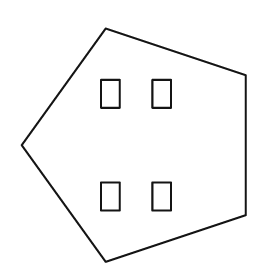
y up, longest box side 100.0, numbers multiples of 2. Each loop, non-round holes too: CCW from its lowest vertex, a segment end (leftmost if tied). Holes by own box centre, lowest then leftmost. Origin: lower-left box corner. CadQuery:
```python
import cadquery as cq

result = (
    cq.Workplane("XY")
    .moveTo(36.0, 0.0)
    .lineTo(96.0, 20.0)
    .lineTo(96.0, 80.0)
    .lineTo(36.0, 100.0)
    .lineTo(0.0, 50.0)
    .close()
    .moveTo(34.0, 22.0)
    .lineTo(42.0, 22.0)
    .lineTo(42.0, 34.0)
    .lineTo(34.0, 34.0)
    .close()
    .moveTo(56.0, 22.0)
    .lineTo(64.0, 22.0)
    .lineTo(64.0, 34.0)
    .lineTo(56.0, 34.0)
    .close()
    .moveTo(34.0, 66.0)
    .lineTo(42.0, 66.0)
    .lineTo(42.0, 78.0)
    .lineTo(34.0, 78.0)
    .close()
    .moveTo(56.0, 66.0)
    .lineTo(64.0, 66.0)
    .lineTo(64.0, 78.0)
    .lineTo(56.0, 78.0)
    .close()
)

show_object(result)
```